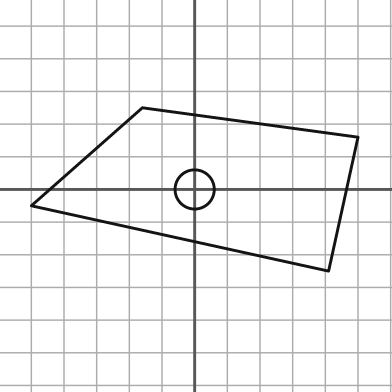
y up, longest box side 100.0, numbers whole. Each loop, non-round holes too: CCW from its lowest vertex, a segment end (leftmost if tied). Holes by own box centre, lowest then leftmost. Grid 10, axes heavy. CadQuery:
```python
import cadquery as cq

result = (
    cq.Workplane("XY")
    .moveTo(41.0, -25.0)
    .lineTo(50.0, 16.0)
    .lineTo(-16.0, 25.0)
    .lineTo(-50.0, -5.0)
    .close()
    .moveTo(0.0, 0.0)
    .circle(6.0)
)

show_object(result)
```